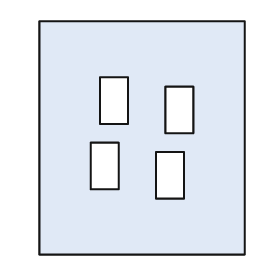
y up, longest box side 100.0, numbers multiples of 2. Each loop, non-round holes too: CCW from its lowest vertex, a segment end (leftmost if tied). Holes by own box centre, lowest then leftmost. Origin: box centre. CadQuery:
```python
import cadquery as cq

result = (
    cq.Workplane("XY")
    .moveTo(-44.0, -50.0)
    .lineTo(44.0, -50.0)
    .lineTo(44.0, 50.0)
    .lineTo(-44.0, 50.0)
    .close()
    .moveTo(6.0, -26.0)
    .lineTo(18.0, -26.0)
    .lineTo(18.0, -6.0)
    .lineTo(6.0, -6.0)
    .close()
    .moveTo(-22.0, -22.0)
    .lineTo(-10.0, -22.0)
    .lineTo(-10.0, -2.0)
    .lineTo(-22.0, -2.0)
    .close()
    .moveTo(10.0, 2.0)
    .lineTo(22.0, 2.0)
    .lineTo(22.0, 22.0)
    .lineTo(10.0, 22.0)
    .close()
    .moveTo(-18.0, 6.0)
    .lineTo(-6.0, 6.0)
    .lineTo(-6.0, 26.0)
    .lineTo(-18.0, 26.0)
    .close()
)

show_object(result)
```